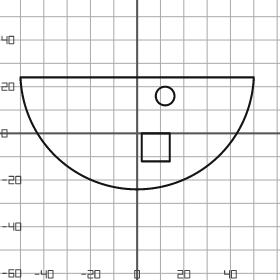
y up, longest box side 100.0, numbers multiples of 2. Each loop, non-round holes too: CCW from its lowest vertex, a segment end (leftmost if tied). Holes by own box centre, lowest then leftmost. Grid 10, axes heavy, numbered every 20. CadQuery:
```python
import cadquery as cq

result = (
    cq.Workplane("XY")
    .moveTo(-50.0, 24.0)
    .threePointArc((0.0, -24.0), (50.0, 24.0))
    .close()
    .moveTo(2.0, -12.0)
    .lineTo(14.0, -12.0)
    .lineTo(14.0, 0.0)
    .lineTo(2.0, 0.0)
    .close()
    .moveTo(12.0, 16.0)
    .circle(4.0)
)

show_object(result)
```